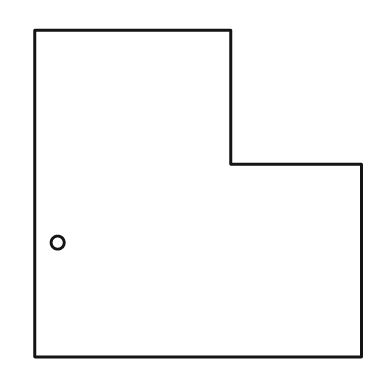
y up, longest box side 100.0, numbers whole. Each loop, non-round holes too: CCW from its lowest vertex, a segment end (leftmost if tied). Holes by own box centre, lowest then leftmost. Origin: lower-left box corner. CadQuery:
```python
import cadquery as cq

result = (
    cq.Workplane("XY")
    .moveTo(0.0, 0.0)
    .lineTo(100.0, 0.0)
    .lineTo(100.0, 59.0)
    .lineTo(60.0, 59.0)
    .lineTo(60.0, 100.0)
    .lineTo(0.0, 100.0)
    .close()
    .moveTo(7.0, 35.0)
    .circle(2.0)
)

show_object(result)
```